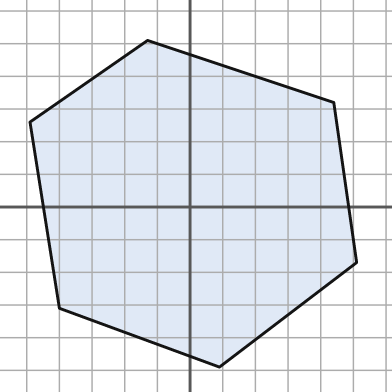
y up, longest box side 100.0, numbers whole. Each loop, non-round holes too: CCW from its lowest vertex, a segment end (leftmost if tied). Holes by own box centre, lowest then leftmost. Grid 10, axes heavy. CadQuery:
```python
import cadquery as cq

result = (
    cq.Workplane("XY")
    .moveTo(9.0, -49.0)
    .lineTo(51.0, -17.0)
    .lineTo(44.0, 32.0)
    .lineTo(-13.0, 51.0)
    .lineTo(-49.0, 26.0)
    .lineTo(-40.0, -31.0)
    .close()
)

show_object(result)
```